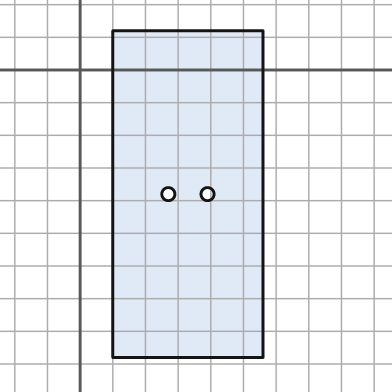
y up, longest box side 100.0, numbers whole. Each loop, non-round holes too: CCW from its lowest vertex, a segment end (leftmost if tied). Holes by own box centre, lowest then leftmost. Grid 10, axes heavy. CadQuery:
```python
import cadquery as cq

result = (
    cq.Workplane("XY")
    .moveTo(10.0, -88.0)
    .lineTo(56.0, -88.0)
    .lineTo(56.0, 12.0)
    .lineTo(10.0, 12.0)
    .close()
    .moveTo(27.0, -38.0)
    .circle(2.0)
    .moveTo(39.0, -38.0)
    .circle(2.0)
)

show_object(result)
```